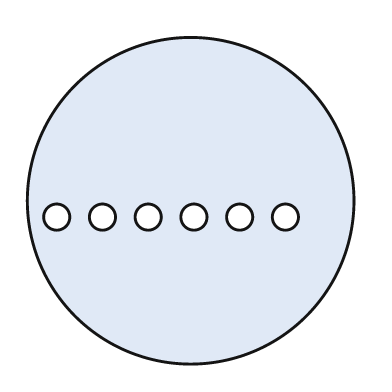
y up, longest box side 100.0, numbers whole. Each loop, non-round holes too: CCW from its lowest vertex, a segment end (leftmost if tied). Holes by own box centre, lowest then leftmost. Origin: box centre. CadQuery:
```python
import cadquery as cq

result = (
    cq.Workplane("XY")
    .moveTo(0.0, 0.0)
    .circle(50.0)
    .moveTo(-41.0, -5.0)
    .circle(4.0)
    .moveTo(-27.0, -5.0)
    .circle(4.0)
    .moveTo(-13.0, -5.0)
    .circle(4.0)
    .moveTo(1.0, -5.0)
    .circle(4.0)
    .moveTo(15.0, -5.0)
    .circle(4.0)
    .moveTo(29.0, -5.0)
    .circle(4.0)
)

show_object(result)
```